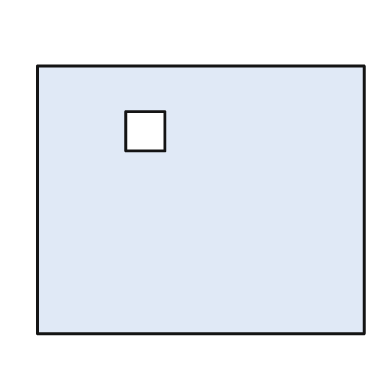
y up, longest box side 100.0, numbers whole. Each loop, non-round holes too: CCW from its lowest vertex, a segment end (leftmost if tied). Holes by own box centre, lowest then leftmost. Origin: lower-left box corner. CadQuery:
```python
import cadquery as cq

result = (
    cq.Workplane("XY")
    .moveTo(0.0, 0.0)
    .lineTo(100.0, 0.0)
    .lineTo(100.0, 82.0)
    .lineTo(0.0, 82.0)
    .close()
    .moveTo(27.0, 56.0)
    .lineTo(39.0, 56.0)
    .lineTo(39.0, 68.0)
    .lineTo(27.0, 68.0)
    .close()
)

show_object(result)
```